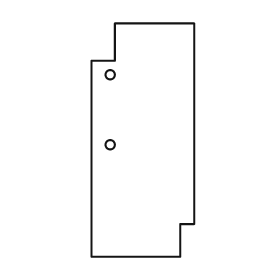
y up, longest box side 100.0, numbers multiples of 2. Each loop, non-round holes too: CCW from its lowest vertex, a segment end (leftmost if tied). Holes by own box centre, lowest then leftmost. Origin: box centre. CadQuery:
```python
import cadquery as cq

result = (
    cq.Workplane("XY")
    .moveTo(-22.0, -50.0)
    .lineTo(16.0, -50.0)
    .lineTo(16.0, -36.0)
    .lineTo(22.0, -36.0)
    .lineTo(22.0, 50.0)
    .lineTo(-12.0, 50.0)
    .lineTo(-12.0, 34.0)
    .lineTo(-22.0, 34.0)
    .close()
    .moveTo(-14.0, -2.0)
    .circle(2.0)
    .moveTo(-14.0, 28.0)
    .circle(2.0)
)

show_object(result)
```